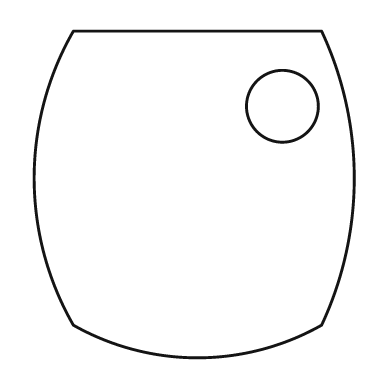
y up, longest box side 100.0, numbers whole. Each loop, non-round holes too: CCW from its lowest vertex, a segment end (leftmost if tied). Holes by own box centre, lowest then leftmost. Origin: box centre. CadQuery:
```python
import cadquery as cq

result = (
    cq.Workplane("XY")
    .moveTo(-37.0, -40.0)
    .threePointArc((1.0, -50.0), (39.0, -40.0))
    .threePointArc((49.0, 5.0), (39.0, 50.0))
    .lineTo(-37.0, 50.0)
    .threePointArc((-49.0, 5.0), (-37.0, -40.0))
    .close()
    .moveTo(27.0, 27.0)
    .circle(11.0)
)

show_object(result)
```